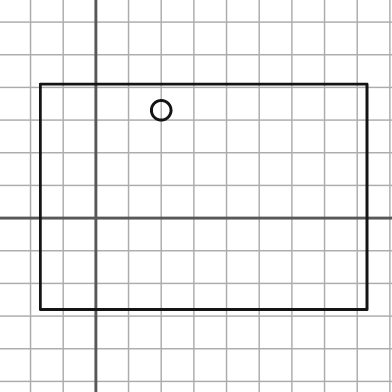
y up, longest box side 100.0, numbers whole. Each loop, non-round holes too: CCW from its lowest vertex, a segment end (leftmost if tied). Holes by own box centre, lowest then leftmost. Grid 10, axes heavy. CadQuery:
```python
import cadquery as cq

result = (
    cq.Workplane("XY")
    .moveTo(-17.0, -28.0)
    .lineTo(83.0, -28.0)
    .lineTo(83.0, 41.0)
    .lineTo(-17.0, 41.0)
    .close()
    .moveTo(20.0, 33.0)
    .circle(3.0)
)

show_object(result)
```